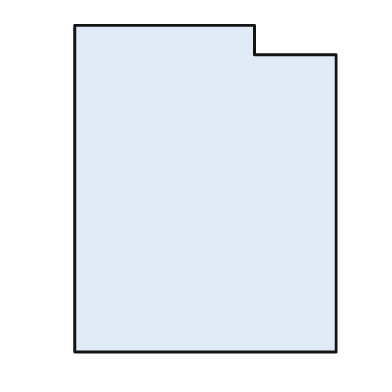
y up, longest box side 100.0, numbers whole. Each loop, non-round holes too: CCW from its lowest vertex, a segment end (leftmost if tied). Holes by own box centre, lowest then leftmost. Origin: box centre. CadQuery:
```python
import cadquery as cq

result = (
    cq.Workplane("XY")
    .moveTo(-40.0, -50.0)
    .lineTo(40.0, -50.0)
    .lineTo(40.0, 41.0)
    .lineTo(15.0, 41.0)
    .lineTo(15.0, 50.0)
    .lineTo(-40.0, 50.0)
    .close()
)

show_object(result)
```